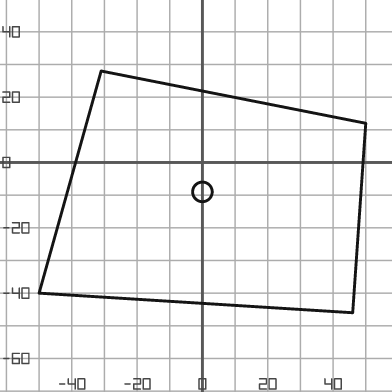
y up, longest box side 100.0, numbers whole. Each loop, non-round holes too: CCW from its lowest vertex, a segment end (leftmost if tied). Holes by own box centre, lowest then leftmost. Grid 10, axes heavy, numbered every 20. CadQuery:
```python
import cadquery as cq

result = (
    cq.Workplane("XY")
    .moveTo(46.0, -46.0)
    .lineTo(50.0, 12.0)
    .lineTo(-31.0, 28.0)
    .lineTo(-50.0, -40.0)
    .close()
    .moveTo(0.0, -9.0)
    .circle(3.0)
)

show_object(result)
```